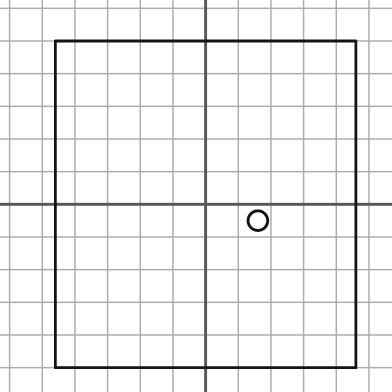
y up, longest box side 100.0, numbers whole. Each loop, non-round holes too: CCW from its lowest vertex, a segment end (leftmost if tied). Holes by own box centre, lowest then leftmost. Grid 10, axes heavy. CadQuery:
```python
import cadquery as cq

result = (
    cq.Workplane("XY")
    .moveTo(-46.0, -50.0)
    .lineTo(46.0, -50.0)
    .lineTo(46.0, 50.0)
    .lineTo(-46.0, 50.0)
    .close()
    .moveTo(16.0, -5.0)
    .circle(3.0)
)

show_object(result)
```